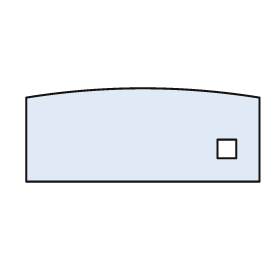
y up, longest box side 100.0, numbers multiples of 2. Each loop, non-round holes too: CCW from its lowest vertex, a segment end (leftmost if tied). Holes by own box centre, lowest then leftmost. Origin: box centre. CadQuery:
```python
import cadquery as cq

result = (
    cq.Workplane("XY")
    .moveTo(-50.0, -20.0)
    .lineTo(50.0, -20.0)
    .lineTo(50.0, 16.0)
    .threePointArc((0.0, 20.0), (-50.0, 16.0))
    .close()
    .moveTo(32.0, -10.0)
    .lineTo(40.0, -10.0)
    .lineTo(40.0, -2.0)
    .lineTo(32.0, -2.0)
    .close()
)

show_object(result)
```